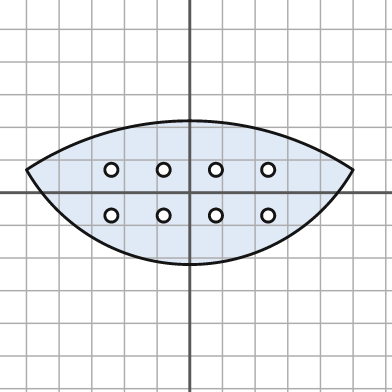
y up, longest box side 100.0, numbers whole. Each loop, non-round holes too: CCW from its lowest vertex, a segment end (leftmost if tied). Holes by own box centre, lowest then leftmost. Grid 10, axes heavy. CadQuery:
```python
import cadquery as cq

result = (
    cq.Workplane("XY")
    .moveTo(-50.0, 7.0)
    .threePointArc((0.0, -22.0), (50.0, 7.0))
    .threePointArc((0.0, 22.0), (-50.0, 7.0))
    .close()
    .moveTo(-24.0, -7.0)
    .circle(2.0)
    .moveTo(-8.0, -7.0)
    .circle(2.0)
    .moveTo(8.0, -7.0)
    .circle(2.0)
    .moveTo(24.0, -7.0)
    .circle(2.0)
    .moveTo(-24.0, 7.0)
    .circle(2.0)
    .moveTo(-8.0, 7.0)
    .circle(2.0)
    .moveTo(8.0, 7.0)
    .circle(2.0)
    .moveTo(24.0, 7.0)
    .circle(2.0)
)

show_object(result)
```